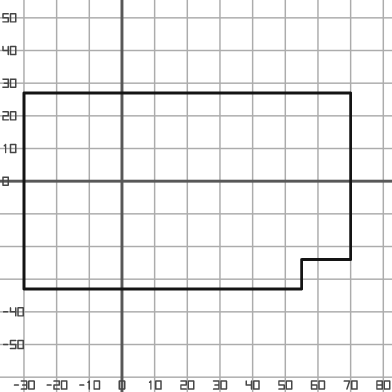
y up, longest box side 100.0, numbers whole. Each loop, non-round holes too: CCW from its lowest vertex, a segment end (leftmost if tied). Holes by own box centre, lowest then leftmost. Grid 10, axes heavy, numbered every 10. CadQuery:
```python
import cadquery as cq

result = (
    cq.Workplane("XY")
    .moveTo(-30.0, -33.0)
    .lineTo(55.0, -33.0)
    .lineTo(55.0, -24.0)
    .lineTo(70.0, -24.0)
    .lineTo(70.0, 27.0)
    .lineTo(-30.0, 27.0)
    .close()
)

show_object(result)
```